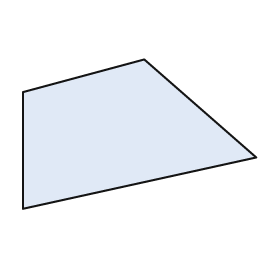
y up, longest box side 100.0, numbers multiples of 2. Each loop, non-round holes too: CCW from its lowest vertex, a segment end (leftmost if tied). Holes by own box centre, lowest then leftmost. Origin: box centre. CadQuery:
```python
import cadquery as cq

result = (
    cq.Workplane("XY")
    .moveTo(-50.0, -32.0)
    .lineTo(50.0, -10.0)
    .lineTo(2.0, 32.0)
    .lineTo(-50.0, 18.0)
    .close()
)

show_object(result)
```